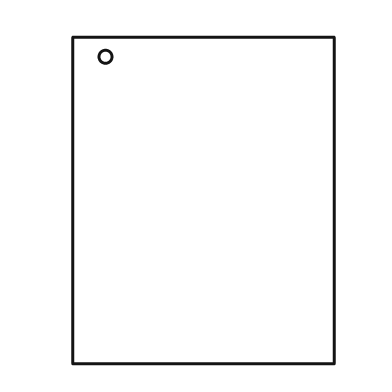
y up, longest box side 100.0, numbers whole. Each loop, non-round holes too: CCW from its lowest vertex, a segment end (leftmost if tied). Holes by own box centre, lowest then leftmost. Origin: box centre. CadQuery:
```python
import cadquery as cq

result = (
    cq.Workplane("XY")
    .moveTo(-40.0, -50.0)
    .lineTo(40.0, -50.0)
    .lineTo(40.0, 50.0)
    .lineTo(-40.0, 50.0)
    .close()
    .moveTo(-30.0, 44.0)
    .circle(2.0)
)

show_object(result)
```